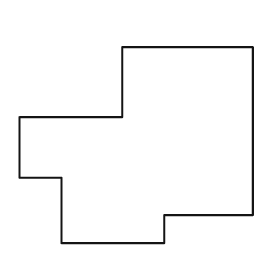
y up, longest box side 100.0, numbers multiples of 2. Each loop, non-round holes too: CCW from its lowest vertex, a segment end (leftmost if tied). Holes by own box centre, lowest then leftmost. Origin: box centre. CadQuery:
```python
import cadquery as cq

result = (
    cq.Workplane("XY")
    .moveTo(-32.0, -42.0)
    .lineTo(12.0, -42.0)
    .lineTo(12.0, -30.0)
    .lineTo(50.0, -30.0)
    .lineTo(50.0, 42.0)
    .lineTo(-6.0, 42.0)
    .lineTo(-6.0, 12.0)
    .lineTo(-50.0, 12.0)
    .lineTo(-50.0, -14.0)
    .lineTo(-32.0, -14.0)
    .close()
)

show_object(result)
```